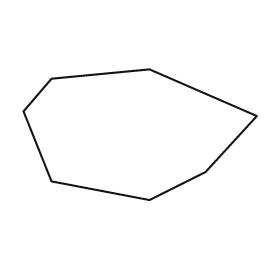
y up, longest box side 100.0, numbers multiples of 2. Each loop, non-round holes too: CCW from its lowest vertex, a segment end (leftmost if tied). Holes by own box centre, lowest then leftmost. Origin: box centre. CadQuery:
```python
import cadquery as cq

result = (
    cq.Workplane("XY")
    .moveTo(4.0, -28.0)
    .lineTo(28.0, -16.0)
    .lineTo(50.0, 8.0)
    .lineTo(4.0, 28.0)
    .lineTo(-38.0, 24.0)
    .lineTo(-50.0, 10.0)
    .lineTo(-38.0, -20.0)
    .close()
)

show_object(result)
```